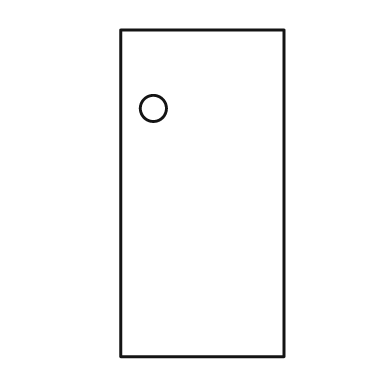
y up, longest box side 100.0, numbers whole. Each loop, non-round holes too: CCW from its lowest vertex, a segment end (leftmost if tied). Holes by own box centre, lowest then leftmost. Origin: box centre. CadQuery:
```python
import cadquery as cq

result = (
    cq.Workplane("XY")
    .moveTo(-25.0, -50.0)
    .lineTo(25.0, -50.0)
    .lineTo(25.0, 50.0)
    .lineTo(-25.0, 50.0)
    .close()
    .moveTo(-15.0, 26.0)
    .circle(4.0)
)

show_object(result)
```